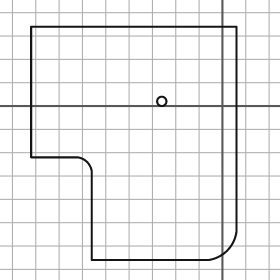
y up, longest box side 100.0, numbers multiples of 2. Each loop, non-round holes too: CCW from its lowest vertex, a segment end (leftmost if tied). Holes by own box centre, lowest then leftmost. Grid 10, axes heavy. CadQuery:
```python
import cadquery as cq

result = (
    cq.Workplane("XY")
    .moveTo(-56.0, -66.0)
    .lineTo(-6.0, -66.0)
    .threePointArc((2.0, -62.0), (6.0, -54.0))
    .lineTo(6.0, 34.0)
    .lineTo(-82.0, 34.0)
    .lineTo(-82.0, -22.0)
    .lineTo(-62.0, -22.0)
    .threePointArc((-58.0, -24.0), (-56.0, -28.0))
    .close()
    .moveTo(-26.0, 2.0)
    .circle(2.0)
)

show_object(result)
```